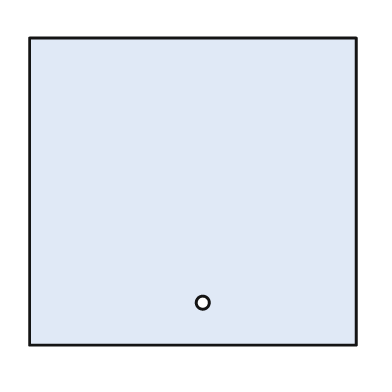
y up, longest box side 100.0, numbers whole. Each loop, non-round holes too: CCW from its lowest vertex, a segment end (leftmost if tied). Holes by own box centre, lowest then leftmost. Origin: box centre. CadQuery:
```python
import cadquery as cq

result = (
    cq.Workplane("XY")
    .moveTo(-50.0, -47.0)
    .lineTo(50.0, -47.0)
    .lineTo(50.0, 47.0)
    .lineTo(-50.0, 47.0)
    .close()
    .moveTo(3.0, -34.0)
    .circle(2.0)
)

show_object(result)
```